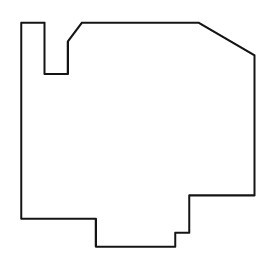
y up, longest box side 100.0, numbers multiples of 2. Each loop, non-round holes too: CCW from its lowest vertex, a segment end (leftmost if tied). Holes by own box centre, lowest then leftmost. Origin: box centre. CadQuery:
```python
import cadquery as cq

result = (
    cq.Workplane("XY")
    .moveTo(-18.0, -48.0)
    .lineTo(16.0, -48.0)
    .lineTo(16.0, -42.0)
    .lineTo(22.0, -42.0)
    .lineTo(22.0, -26.0)
    .lineTo(50.0, -26.0)
    .lineTo(50.0, 34.0)
    .lineTo(26.0, 48.0)
    .lineTo(-24.0, 48.0)
    .lineTo(-30.0, 40.0)
    .lineTo(-30.0, 26.0)
    .lineTo(-40.0, 26.0)
    .lineTo(-40.0, 48.0)
    .lineTo(-50.0, 48.0)
    .lineTo(-50.0, -36.0)
    .lineTo(-18.0, -36.0)
    .close()
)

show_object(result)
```